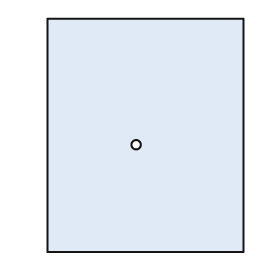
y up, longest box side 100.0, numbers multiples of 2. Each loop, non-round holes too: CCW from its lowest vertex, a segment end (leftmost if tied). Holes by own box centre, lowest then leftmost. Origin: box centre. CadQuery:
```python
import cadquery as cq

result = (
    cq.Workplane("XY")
    .moveTo(-42.0, -50.0)
    .lineTo(42.0, -50.0)
    .lineTo(42.0, 50.0)
    .lineTo(-42.0, 50.0)
    .close()
    .moveTo(-4.0, -4.0)
    .circle(2.0)
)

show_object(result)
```